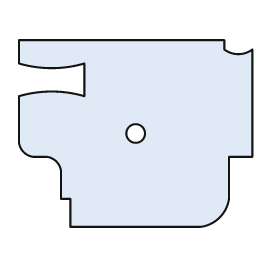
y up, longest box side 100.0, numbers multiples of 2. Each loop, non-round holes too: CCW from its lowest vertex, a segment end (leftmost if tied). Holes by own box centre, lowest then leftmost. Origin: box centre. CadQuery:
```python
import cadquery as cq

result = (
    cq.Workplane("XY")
    .moveTo(-28.0, -40.0)
    .lineTo(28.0, -40.0)
    .threePointArc((36.0, -36.0), (40.0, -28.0))
    .lineTo(40.0, -10.0)
    .lineTo(50.0, -10.0)
    .lineTo(50.0, 36.0)
    .threePointArc((44.0, 34.0), (38.0, 36.0))
    .lineTo(38.0, 40.0)
    .lineTo(-50.0, 40.0)
    .lineTo(-50.0, 30.0)
    .threePointArc((-36.0, 28.0), (-22.0, 30.0))
    .lineTo(-22.0, 16.0)
    .threePointArc((-36.0, 18.0), (-50.0, 16.0))
    .lineTo(-50.0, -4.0)
    .threePointArc((-48.0, -8.0), (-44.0, -10.0))
    .lineTo(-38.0, -10.0)
    .threePointArc((-34.0, -12.0), (-32.0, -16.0))
    .lineTo(-32.0, -28.0)
    .lineTo(-28.0, -28.0)
    .close()
    .moveTo(0.0, 0.0)
    .circle(4.0)
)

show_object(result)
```